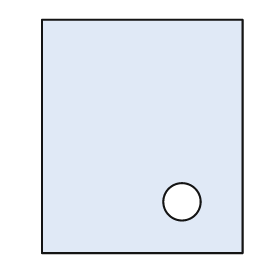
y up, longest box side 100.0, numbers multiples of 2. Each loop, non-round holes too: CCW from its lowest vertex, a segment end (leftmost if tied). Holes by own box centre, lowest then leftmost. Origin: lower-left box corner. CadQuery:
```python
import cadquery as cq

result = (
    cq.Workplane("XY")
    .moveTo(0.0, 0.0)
    .lineTo(86.0, 0.0)
    .lineTo(86.0, 100.0)
    .lineTo(0.0, 100.0)
    .close()
    .moveTo(60.0, 22.0)
    .circle(8.0)
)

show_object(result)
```